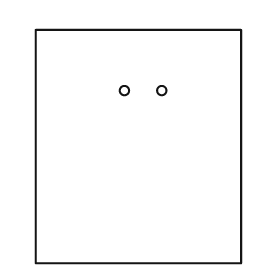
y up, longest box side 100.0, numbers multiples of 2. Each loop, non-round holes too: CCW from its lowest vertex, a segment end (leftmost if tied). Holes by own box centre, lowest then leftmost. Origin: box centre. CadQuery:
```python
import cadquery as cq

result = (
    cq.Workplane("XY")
    .moveTo(-44.0, -50.0)
    .lineTo(44.0, -50.0)
    .lineTo(44.0, 50.0)
    .lineTo(-44.0, 50.0)
    .close()
    .moveTo(-6.0, 24.0)
    .circle(2.0)
    .moveTo(10.0, 24.0)
    .circle(2.0)
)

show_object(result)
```